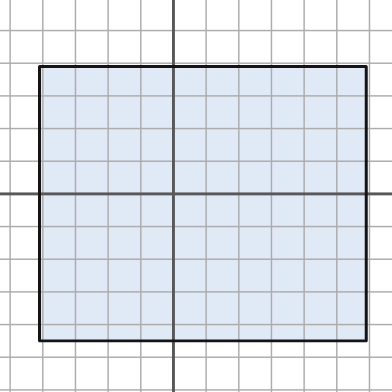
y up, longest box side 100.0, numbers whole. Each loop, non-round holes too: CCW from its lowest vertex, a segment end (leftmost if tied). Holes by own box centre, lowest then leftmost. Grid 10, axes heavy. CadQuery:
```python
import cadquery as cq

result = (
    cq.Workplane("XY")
    .moveTo(-41.0, -45.0)
    .lineTo(59.0, -45.0)
    .lineTo(59.0, 39.0)
    .lineTo(-41.0, 39.0)
    .close()
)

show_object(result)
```